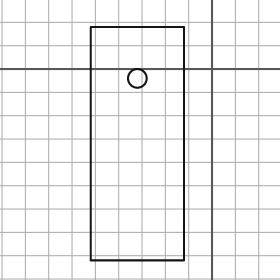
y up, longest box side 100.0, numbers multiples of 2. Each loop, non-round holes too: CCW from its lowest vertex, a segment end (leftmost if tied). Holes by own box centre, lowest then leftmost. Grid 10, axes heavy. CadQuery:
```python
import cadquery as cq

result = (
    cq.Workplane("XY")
    .moveTo(-52.0, -82.0)
    .lineTo(-12.0, -82.0)
    .lineTo(-12.0, 18.0)
    .lineTo(-52.0, 18.0)
    .close()
    .moveTo(-32.0, -4.0)
    .circle(4.0)
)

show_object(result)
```